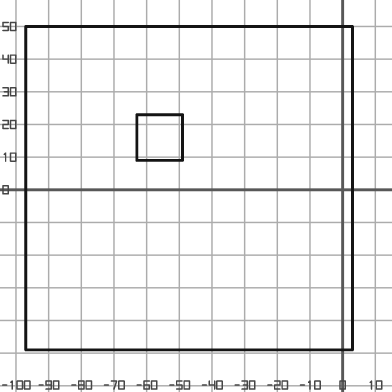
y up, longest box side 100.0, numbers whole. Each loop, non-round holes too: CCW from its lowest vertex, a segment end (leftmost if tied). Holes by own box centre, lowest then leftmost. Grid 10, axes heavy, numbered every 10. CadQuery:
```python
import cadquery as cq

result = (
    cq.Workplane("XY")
    .moveTo(-97.0, -49.0)
    .lineTo(3.0, -49.0)
    .lineTo(3.0, 50.0)
    .lineTo(-97.0, 50.0)
    .close()
    .moveTo(-63.0, 9.0)
    .lineTo(-49.0, 9.0)
    .lineTo(-49.0, 23.0)
    .lineTo(-63.0, 23.0)
    .close()
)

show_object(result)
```